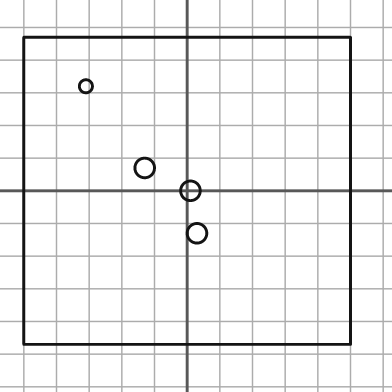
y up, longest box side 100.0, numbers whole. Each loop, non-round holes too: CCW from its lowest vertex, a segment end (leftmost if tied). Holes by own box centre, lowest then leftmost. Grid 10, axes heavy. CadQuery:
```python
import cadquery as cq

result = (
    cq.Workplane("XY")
    .moveTo(-50.0, -47.0)
    .lineTo(50.0, -47.0)
    .lineTo(50.0, 47.0)
    .lineTo(-50.0, 47.0)
    .close()
    .moveTo(3.0, -13.0)
    .circle(3.0)
    .moveTo(1.0, 0.0)
    .circle(3.0)
    .moveTo(-13.0, 7.0)
    .circle(3.0)
    .moveTo(-31.0, 32.0)
    .circle(2.0)
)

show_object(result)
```